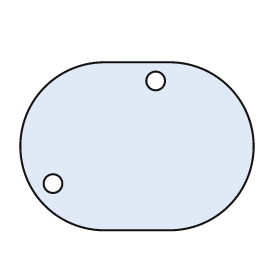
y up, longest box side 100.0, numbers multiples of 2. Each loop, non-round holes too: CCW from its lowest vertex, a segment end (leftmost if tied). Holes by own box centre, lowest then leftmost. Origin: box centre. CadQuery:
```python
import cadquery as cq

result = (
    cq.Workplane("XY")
    .moveTo(-14.0, -36.0)
    .lineTo(14.0, -36.0)
    .threePointArc((50.0, 0.0), (14.0, 36.0))
    .lineTo(-14.0, 36.0)
    .threePointArc((-50.0, 0.0), (-14.0, -36.0))
    .close()
    .moveTo(-36.0, -16.0)
    .circle(4.0)
    .moveTo(8.0, 28.0)
    .circle(4.0)
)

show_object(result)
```